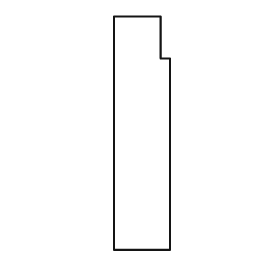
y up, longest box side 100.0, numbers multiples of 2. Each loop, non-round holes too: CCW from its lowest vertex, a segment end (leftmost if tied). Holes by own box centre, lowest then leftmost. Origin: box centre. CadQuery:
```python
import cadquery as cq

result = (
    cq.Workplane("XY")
    .moveTo(-12.0, -50.0)
    .lineTo(12.0, -50.0)
    .lineTo(12.0, 32.0)
    .lineTo(8.0, 32.0)
    .lineTo(8.0, 50.0)
    .lineTo(-12.0, 50.0)
    .close()
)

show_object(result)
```